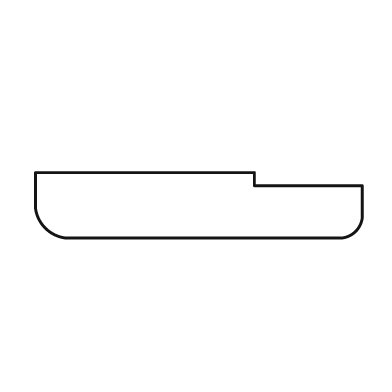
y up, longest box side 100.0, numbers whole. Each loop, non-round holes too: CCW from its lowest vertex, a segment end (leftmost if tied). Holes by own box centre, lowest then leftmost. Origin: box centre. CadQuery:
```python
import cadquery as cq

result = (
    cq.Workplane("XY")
    .moveTo(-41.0, -10.0)
    .lineTo(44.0, -10.0)
    .threePointArc((48.0, -8.0), (50.0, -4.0))
    .lineTo(50.0, 6.0)
    .lineTo(17.0, 6.0)
    .lineTo(17.0, 10.0)
    .lineTo(-50.0, 10.0)
    .lineTo(-50.0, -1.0)
    .threePointArc((-47.0, -7.0), (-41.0, -10.0))
    .close()
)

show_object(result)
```